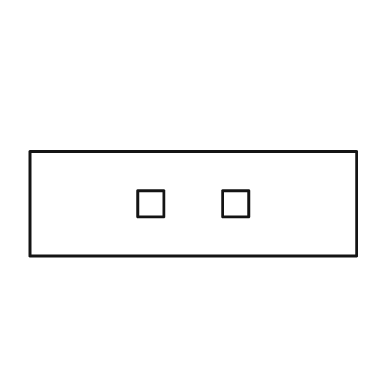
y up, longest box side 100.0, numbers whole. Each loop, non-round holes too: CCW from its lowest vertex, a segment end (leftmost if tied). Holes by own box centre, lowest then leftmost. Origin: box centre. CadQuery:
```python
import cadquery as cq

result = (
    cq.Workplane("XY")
    .moveTo(-50.0, -16.0)
    .lineTo(50.0, -16.0)
    .lineTo(50.0, 16.0)
    .lineTo(-50.0, 16.0)
    .close()
    .moveTo(-17.0, -4.0)
    .lineTo(-9.0, -4.0)
    .lineTo(-9.0, 4.0)
    .lineTo(-17.0, 4.0)
    .close()
    .moveTo(9.0, -4.0)
    .lineTo(17.0, -4.0)
    .lineTo(17.0, 4.0)
    .lineTo(9.0, 4.0)
    .close()
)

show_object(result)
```